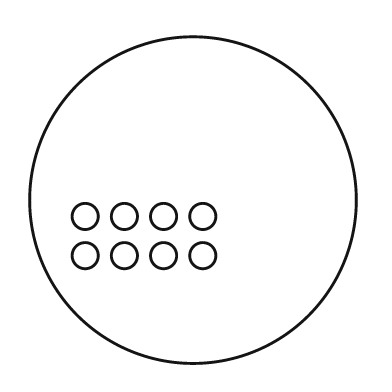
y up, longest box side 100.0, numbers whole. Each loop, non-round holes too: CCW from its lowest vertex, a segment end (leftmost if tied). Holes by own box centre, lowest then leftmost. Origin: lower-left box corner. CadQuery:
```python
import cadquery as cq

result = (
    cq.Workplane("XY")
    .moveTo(50.0, 50.0)
    .circle(50.0)
    .moveTo(17.0, 33.0)
    .circle(4.0)
    .moveTo(29.0, 33.0)
    .circle(4.0)
    .moveTo(41.0, 33.0)
    .circle(4.0)
    .moveTo(53.0, 33.0)
    .circle(4.0)
    .moveTo(17.0, 45.0)
    .circle(4.0)
    .moveTo(29.0, 45.0)
    .circle(4.0)
    .moveTo(41.0, 45.0)
    .circle(4.0)
    .moveTo(53.0, 45.0)
    .circle(4.0)
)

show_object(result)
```